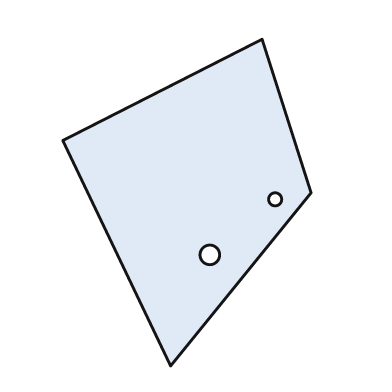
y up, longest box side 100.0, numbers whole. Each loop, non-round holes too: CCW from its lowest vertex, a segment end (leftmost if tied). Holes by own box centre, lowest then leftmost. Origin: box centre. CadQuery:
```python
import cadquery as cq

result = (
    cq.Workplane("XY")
    .moveTo(-5.0, -50.0)
    .lineTo(38.0, 3.0)
    .lineTo(23.0, 50.0)
    .lineTo(-38.0, 19.0)
    .close()
    .moveTo(7.0, -16.0)
    .circle(3.0)
    .moveTo(27.0, 1.0)
    .circle(2.0)
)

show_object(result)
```